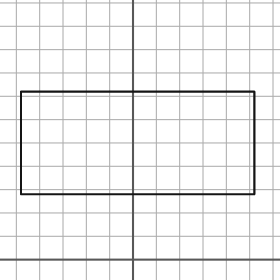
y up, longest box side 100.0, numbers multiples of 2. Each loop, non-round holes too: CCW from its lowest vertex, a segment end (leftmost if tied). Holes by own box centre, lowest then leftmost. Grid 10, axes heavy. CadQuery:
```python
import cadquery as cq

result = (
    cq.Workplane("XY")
    .moveTo(-48.0, 28.0)
    .lineTo(52.0, 28.0)
    .lineTo(52.0, 72.0)
    .lineTo(-48.0, 72.0)
    .close()
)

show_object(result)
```